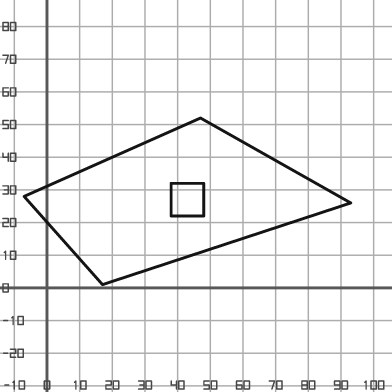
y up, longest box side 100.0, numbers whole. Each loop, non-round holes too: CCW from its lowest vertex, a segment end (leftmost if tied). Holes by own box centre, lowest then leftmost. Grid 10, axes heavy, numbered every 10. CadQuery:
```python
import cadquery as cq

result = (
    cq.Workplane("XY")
    .moveTo(17.0, 1.0)
    .lineTo(93.0, 26.0)
    .lineTo(47.0, 52.0)
    .lineTo(-7.0, 28.0)
    .close()
    .moveTo(38.0, 22.0)
    .lineTo(48.0, 22.0)
    .lineTo(48.0, 32.0)
    .lineTo(38.0, 32.0)
    .close()
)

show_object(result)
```